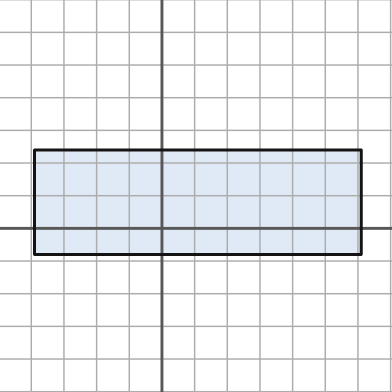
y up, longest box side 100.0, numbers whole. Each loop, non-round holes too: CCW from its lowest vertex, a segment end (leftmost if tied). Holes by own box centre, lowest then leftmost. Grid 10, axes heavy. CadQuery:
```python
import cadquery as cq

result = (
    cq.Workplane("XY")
    .moveTo(-39.0, -8.0)
    .lineTo(61.0, -8.0)
    .lineTo(61.0, 24.0)
    .lineTo(-39.0, 24.0)
    .close()
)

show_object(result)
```